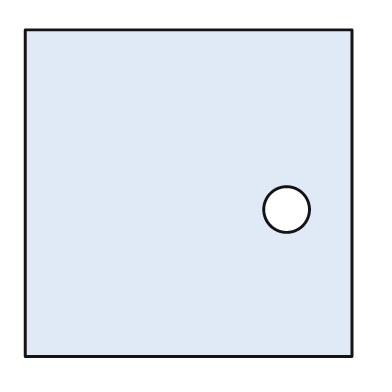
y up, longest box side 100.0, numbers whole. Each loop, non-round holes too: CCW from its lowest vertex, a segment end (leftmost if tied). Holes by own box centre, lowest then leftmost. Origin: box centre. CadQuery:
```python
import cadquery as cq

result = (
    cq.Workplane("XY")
    .moveTo(-50.0, -50.0)
    .lineTo(50.0, -50.0)
    .lineTo(50.0, 50.0)
    .lineTo(-50.0, 50.0)
    .close()
    .moveTo(30.0, -5.0)
    .circle(7.0)
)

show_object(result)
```